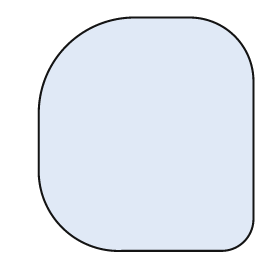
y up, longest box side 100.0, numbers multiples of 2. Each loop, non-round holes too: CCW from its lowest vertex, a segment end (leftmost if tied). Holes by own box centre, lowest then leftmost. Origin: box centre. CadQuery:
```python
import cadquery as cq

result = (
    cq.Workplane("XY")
    .moveTo(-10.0, -50.0)
    .lineTo(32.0, -50.0)
    .threePointArc((42.0, -46.0), (46.0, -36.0))
    .lineTo(46.0, 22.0)
    .threePointArc((38.0, 42.0), (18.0, 50.0))
    .lineTo(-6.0, 50.0)
    .threePointArc((-34.0, 38.0), (-46.0, 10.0))
    .lineTo(-46.0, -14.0)
    .threePointArc((-36.0, -40.0), (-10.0, -50.0))
    .close()
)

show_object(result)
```